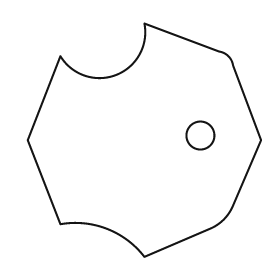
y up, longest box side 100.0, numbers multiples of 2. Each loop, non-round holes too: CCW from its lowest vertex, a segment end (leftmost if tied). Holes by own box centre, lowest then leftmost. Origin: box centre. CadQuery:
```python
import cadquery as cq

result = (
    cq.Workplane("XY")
    .moveTo(0.0, -50.0)
    .lineTo(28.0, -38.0)
    .threePointArc((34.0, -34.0), (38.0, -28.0))
    .lineTo(50.0, 0.0)
    .lineTo(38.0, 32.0)
    .threePointArc((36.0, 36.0), (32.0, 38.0))
    .lineTo(0.0, 50.0)
    .threePointArc((-12.0, 28.0), (-36.0, 36.0))
    .lineTo(-50.0, 0.0)
    .lineTo(-36.0, -36.0)
    .threePointArc((-16.0, -38.0), (0.0, -50.0))
    .close()
    .moveTo(24.0, 2.0)
    .circle(6.0)
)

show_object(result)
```